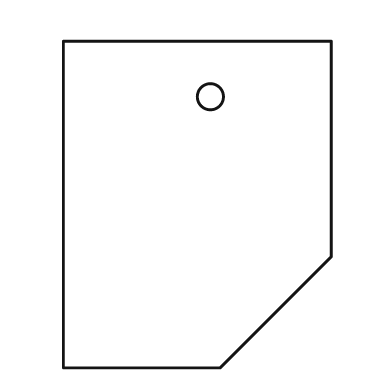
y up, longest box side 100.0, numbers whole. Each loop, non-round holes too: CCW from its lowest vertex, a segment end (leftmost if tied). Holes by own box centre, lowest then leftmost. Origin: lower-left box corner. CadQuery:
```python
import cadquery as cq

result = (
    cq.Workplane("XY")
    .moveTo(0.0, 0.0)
    .lineTo(48.0, 0.0)
    .lineTo(82.0, 34.0)
    .lineTo(82.0, 100.0)
    .lineTo(0.0, 100.0)
    .close()
    .moveTo(45.0, 83.0)
    .circle(4.0)
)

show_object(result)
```